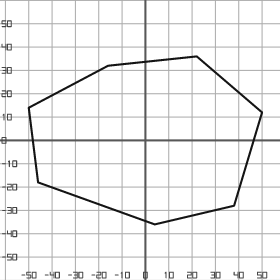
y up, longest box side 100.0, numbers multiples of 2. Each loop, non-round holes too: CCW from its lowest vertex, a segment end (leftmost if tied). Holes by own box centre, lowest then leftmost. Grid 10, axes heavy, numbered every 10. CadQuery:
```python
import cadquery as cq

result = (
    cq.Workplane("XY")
    .moveTo(4.0, -36.0)
    .lineTo(38.0, -28.0)
    .lineTo(50.0, 12.0)
    .lineTo(22.0, 36.0)
    .lineTo(-16.0, 32.0)
    .lineTo(-50.0, 14.0)
    .lineTo(-46.0, -18.0)
    .close()
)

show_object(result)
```